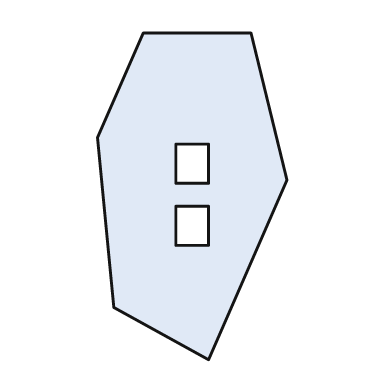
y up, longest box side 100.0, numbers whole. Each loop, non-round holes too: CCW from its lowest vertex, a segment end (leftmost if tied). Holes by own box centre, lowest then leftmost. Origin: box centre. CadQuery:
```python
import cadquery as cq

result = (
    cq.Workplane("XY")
    .moveTo(5.0, -50.0)
    .lineTo(29.0, 5.0)
    .lineTo(18.0, 50.0)
    .lineTo(-15.0, 50.0)
    .lineTo(-29.0, 18.0)
    .lineTo(-24.0, -34.0)
    .close()
    .moveTo(-5.0, -15.0)
    .lineTo(5.0, -15.0)
    .lineTo(5.0, -3.0)
    .lineTo(-5.0, -3.0)
    .close()
    .moveTo(-5.0, 4.0)
    .lineTo(5.0, 4.0)
    .lineTo(5.0, 16.0)
    .lineTo(-5.0, 16.0)
    .close()
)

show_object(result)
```